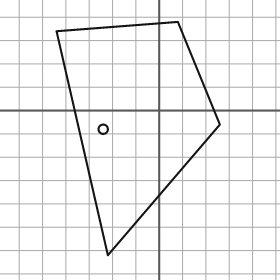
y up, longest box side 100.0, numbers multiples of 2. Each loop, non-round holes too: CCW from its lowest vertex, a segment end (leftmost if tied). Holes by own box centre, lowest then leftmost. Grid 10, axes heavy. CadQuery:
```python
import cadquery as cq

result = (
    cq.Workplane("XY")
    .moveTo(-22.0, -62.0)
    .lineTo(26.0, -6.0)
    .lineTo(8.0, 38.0)
    .lineTo(-44.0, 34.0)
    .close()
    .moveTo(-24.0, -8.0)
    .circle(2.0)
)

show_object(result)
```